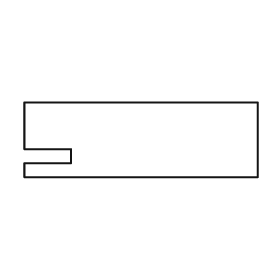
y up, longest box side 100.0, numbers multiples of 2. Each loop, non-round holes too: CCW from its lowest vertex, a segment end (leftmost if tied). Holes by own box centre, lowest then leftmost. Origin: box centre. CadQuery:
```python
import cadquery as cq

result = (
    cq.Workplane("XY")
    .moveTo(-50.0, -16.0)
    .lineTo(50.0, -16.0)
    .lineTo(50.0, 16.0)
    .lineTo(-50.0, 16.0)
    .lineTo(-50.0, -4.0)
    .lineTo(-30.0, -4.0)
    .lineTo(-30.0, -10.0)
    .lineTo(-50.0, -10.0)
    .close()
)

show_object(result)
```